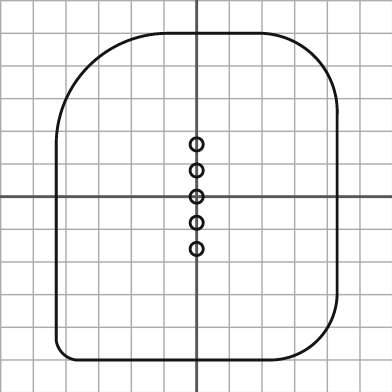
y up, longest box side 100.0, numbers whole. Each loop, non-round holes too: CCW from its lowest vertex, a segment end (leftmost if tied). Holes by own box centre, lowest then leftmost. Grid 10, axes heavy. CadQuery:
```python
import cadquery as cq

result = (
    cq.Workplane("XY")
    .moveTo(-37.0, -50.0)
    .lineTo(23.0, -50.0)
    .threePointArc((37.0, -44.0), (43.0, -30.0))
    .lineTo(43.0, 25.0)
    .threePointArc((36.0, 43.0), (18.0, 50.0))
    .lineTo(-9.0, 50.0)
    .threePointArc((-33.0, 40.0), (-43.0, 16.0))
    .lineTo(-43.0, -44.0)
    .threePointArc((-41.0, -48.0), (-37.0, -50.0))
    .close()
    .moveTo(0.0, -16.0)
    .circle(2.0)
    .moveTo(0.0, -8.0)
    .circle(2.0)
    .moveTo(0.0, 0.0)
    .circle(2.0)
    .moveTo(0.0, 8.0)
    .circle(2.0)
    .moveTo(0.0, 16.0)
    .circle(2.0)
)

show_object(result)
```